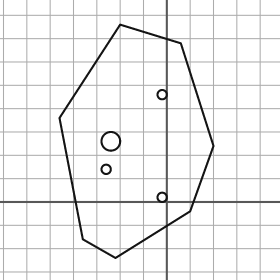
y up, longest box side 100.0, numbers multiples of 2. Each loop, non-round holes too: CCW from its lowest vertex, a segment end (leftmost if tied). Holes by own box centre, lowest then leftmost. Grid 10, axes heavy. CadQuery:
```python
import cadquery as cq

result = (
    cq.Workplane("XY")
    .moveTo(-22.0, -24.0)
    .lineTo(10.0, -4.0)
    .lineTo(20.0, 24.0)
    .lineTo(6.0, 68.0)
    .lineTo(-20.0, 76.0)
    .lineTo(-46.0, 36.0)
    .lineTo(-36.0, -16.0)
    .close()
    .moveTo(-2.0, 2.0)
    .circle(2.0)
    .moveTo(-26.0, 14.0)
    .circle(2.0)
    .moveTo(-24.0, 26.0)
    .circle(4.0)
    .moveTo(-2.0, 46.0)
    .circle(2.0)
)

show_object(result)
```